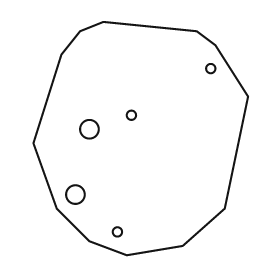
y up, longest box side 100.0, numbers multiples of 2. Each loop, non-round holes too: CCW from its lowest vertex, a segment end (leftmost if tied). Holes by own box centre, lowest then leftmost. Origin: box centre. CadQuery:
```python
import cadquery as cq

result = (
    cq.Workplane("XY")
    .moveTo(-6.0, -50.0)
    .lineTo(18.0, -46.0)
    .lineTo(36.0, -30.0)
    .lineTo(46.0, 18.0)
    .lineTo(32.0, 40.0)
    .lineTo(24.0, 46.0)
    .lineTo(-16.0, 50.0)
    .lineTo(-26.0, 46.0)
    .lineTo(-34.0, 36.0)
    .lineTo(-46.0, -2.0)
    .lineTo(-36.0, -30.0)
    .lineTo(-22.0, -44.0)
    .close()
    .moveTo(-10.0, -40.0)
    .circle(2.0)
    .moveTo(-28.0, -24.0)
    .circle(4.0)
    .moveTo(-22.0, 4.0)
    .circle(4.0)
    .moveTo(-4.0, 10.0)
    .circle(2.0)
    .moveTo(30.0, 30.0)
    .circle(2.0)
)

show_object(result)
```